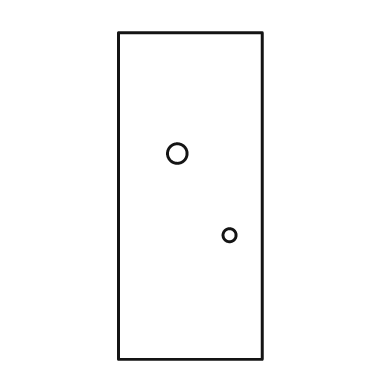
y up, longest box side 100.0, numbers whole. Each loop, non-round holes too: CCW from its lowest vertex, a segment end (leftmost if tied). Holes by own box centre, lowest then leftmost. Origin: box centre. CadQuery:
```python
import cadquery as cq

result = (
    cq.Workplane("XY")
    .moveTo(-22.0, -50.0)
    .lineTo(22.0, -50.0)
    .lineTo(22.0, 50.0)
    .lineTo(-22.0, 50.0)
    .close()
    .moveTo(12.0, -12.0)
    .circle(2.0)
    .moveTo(-4.0, 13.0)
    .circle(3.0)
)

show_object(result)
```